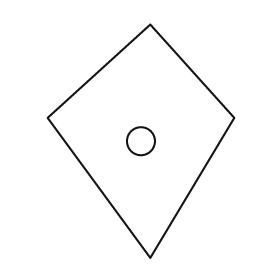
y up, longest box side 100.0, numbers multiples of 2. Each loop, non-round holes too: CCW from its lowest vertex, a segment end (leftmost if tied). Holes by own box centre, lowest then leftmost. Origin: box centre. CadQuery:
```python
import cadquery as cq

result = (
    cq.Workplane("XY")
    .moveTo(4.0, -50.0)
    .lineTo(40.0, 10.0)
    .lineTo(4.0, 50.0)
    .lineTo(-40.0, 10.0)
    .close()
    .moveTo(0.0, 0.0)
    .circle(6.0)
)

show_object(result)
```